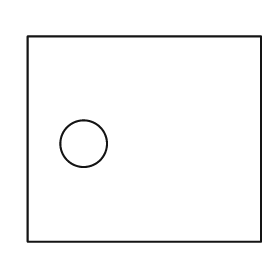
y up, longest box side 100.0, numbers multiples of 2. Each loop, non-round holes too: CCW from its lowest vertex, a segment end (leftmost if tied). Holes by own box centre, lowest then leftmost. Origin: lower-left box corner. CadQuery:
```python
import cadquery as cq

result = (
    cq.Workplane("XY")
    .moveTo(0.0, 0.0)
    .lineTo(100.0, 0.0)
    .lineTo(100.0, 88.0)
    .lineTo(0.0, 88.0)
    .close()
    .moveTo(24.0, 42.0)
    .circle(10.0)
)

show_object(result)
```